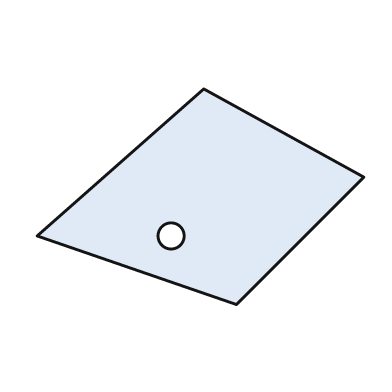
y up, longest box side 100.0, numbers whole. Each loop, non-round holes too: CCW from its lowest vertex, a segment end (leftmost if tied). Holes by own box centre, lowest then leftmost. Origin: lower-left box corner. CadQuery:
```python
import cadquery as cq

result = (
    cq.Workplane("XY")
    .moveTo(61.0, 0.0)
    .lineTo(100.0, 39.0)
    .lineTo(51.0, 66.0)
    .lineTo(0.0, 21.0)
    .close()
    .moveTo(41.0, 21.0)
    .circle(4.0)
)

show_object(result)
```